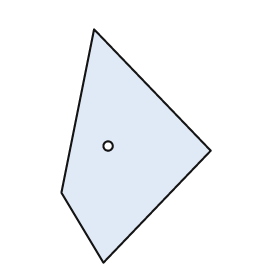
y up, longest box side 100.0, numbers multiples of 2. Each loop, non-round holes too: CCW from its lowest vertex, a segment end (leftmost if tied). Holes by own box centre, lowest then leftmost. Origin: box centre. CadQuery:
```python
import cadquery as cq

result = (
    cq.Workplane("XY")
    .moveTo(-14.0, -50.0)
    .lineTo(32.0, -2.0)
    .lineTo(-18.0, 50.0)
    .lineTo(-32.0, -20.0)
    .close()
    .moveTo(-12.0, 0.0)
    .circle(2.0)
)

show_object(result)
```